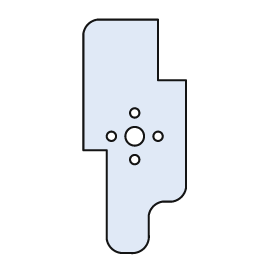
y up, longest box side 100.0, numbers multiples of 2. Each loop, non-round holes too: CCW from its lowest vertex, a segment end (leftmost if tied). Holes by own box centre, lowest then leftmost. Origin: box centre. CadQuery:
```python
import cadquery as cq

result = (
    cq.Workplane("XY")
    .moveTo(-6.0, -50.0)
    .lineTo(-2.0, -50.0)
    .threePointArc((4.0, -48.0), (6.0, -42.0))
    .lineTo(6.0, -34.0)
    .threePointArc((8.0, -30.0), (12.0, -28.0))
    .lineTo(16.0, -28.0)
    .threePointArc((20.0, -26.0), (22.0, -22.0))
    .lineTo(22.0, 24.0)
    .lineTo(10.0, 24.0)
    .lineTo(10.0, 50.0)
    .lineTo(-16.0, 50.0)
    .threePointArc((-20.0, 48.0), (-22.0, 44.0))
    .lineTo(-22.0, -6.0)
    .lineTo(-12.0, -6.0)
    .lineTo(-12.0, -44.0)
    .threePointArc((-10.0, -48.0), (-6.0, -50.0))
    .close()
    .moveTo(0.0, -10.0)
    .circle(2.0)
    .moveTo(-10.0, 0.0)
    .circle(2.0)
    .moveTo(0.0, 0.0)
    .circle(4.0)
    .moveTo(10.0, 0.0)
    .circle(2.0)
    .moveTo(0.0, 10.0)
    .circle(2.0)
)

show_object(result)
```